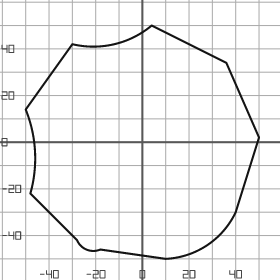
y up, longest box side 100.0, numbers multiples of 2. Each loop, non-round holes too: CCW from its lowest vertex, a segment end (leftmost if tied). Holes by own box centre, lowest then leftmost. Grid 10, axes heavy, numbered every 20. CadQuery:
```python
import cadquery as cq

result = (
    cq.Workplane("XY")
    .moveTo(10.0, -50.0)
    .threePointArc((28.0, -44.0), (40.0, -30.0))
    .lineTo(50.0, 2.0)
    .lineTo(36.0, 34.0)
    .lineTo(4.0, 50.0)
    .threePointArc((-12.0, 42.0), (-30.0, 42.0))
    .lineTo(-50.0, 14.0)
    .threePointArc((-46.0, -4.0), (-48.0, -22.0))
    .lineTo(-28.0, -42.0)
    .threePointArc((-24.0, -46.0), (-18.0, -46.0))
    .close()
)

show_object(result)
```